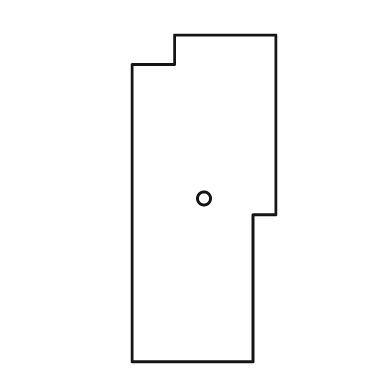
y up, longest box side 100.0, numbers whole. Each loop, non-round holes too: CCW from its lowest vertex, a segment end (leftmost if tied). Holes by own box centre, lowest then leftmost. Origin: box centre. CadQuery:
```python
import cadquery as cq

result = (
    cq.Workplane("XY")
    .moveTo(-22.0, -50.0)
    .lineTo(15.0, -50.0)
    .lineTo(15.0, -5.0)
    .lineTo(22.0, -5.0)
    .lineTo(22.0, 50.0)
    .lineTo(-9.0, 50.0)
    .lineTo(-9.0, 41.0)
    .lineTo(-22.0, 41.0)
    .close()
    .moveTo(0.0, 0.0)
    .circle(2.0)
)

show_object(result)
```